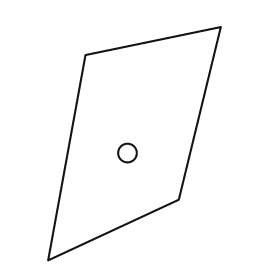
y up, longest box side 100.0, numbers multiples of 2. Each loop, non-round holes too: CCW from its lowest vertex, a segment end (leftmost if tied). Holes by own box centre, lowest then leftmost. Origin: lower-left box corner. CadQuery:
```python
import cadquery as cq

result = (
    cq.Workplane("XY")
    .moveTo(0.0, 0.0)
    .lineTo(56.0, 26.0)
    .lineTo(74.0, 100.0)
    .lineTo(16.0, 88.0)
    .close()
    .moveTo(34.0, 46.0)
    .circle(4.0)
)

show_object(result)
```